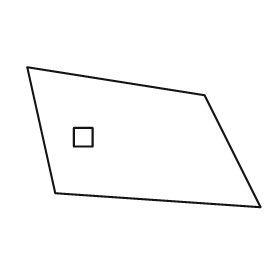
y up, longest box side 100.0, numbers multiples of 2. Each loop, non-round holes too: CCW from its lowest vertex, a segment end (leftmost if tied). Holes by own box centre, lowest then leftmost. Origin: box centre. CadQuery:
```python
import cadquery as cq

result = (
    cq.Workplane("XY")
    .moveTo(50.0, -30.0)
    .lineTo(26.0, 18.0)
    .lineTo(-50.0, 30.0)
    .lineTo(-38.0, -24.0)
    .close()
    .moveTo(-30.0, -4.0)
    .lineTo(-22.0, -4.0)
    .lineTo(-22.0, 4.0)
    .lineTo(-30.0, 4.0)
    .close()
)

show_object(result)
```